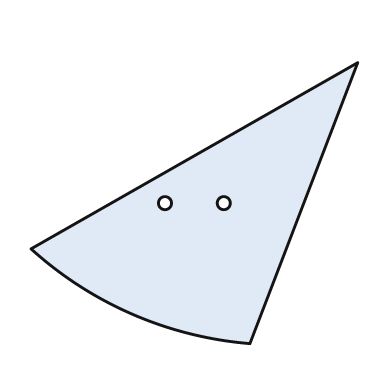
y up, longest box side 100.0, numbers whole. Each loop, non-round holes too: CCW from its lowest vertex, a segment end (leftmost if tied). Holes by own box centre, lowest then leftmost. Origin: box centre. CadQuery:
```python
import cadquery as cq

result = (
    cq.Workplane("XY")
    .moveTo(17.0, -43.0)
    .lineTo(50.0, 43.0)
    .lineTo(-50.0, -14.0)
    .threePointArc((-19.0, -34.0), (17.0, -43.0))
    .close()
    .moveTo(-9.0, 0.0)
    .circle(2.0)
    .moveTo(9.0, 0.0)
    .circle(2.0)
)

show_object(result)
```